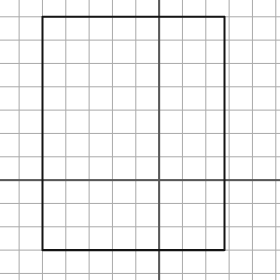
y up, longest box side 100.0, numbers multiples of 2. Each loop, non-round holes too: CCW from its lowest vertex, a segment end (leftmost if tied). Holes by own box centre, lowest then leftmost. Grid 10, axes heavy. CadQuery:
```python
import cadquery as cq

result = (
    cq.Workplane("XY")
    .moveTo(-50.0, -30.0)
    .lineTo(28.0, -30.0)
    .lineTo(28.0, 70.0)
    .lineTo(-50.0, 70.0)
    .close()
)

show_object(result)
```